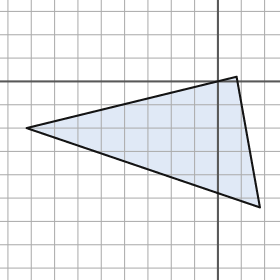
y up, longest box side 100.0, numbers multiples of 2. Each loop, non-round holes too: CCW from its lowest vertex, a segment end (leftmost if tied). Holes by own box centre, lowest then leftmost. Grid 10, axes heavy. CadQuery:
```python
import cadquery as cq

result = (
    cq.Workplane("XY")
    .moveTo(18.0, -54.0)
    .lineTo(8.0, 2.0)
    .lineTo(-82.0, -20.0)
    .close()
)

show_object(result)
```